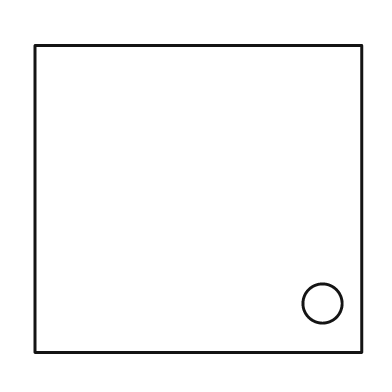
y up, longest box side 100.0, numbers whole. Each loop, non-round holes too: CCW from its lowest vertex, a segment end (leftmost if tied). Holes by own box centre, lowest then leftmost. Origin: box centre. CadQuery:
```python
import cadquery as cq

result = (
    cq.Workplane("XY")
    .moveTo(-50.0, -47.0)
    .lineTo(50.0, -47.0)
    .lineTo(50.0, 47.0)
    .lineTo(-50.0, 47.0)
    .close()
    .moveTo(38.0, -32.0)
    .circle(6.0)
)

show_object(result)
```